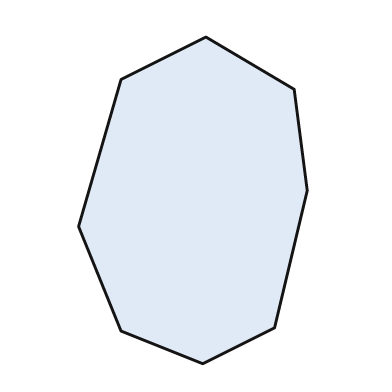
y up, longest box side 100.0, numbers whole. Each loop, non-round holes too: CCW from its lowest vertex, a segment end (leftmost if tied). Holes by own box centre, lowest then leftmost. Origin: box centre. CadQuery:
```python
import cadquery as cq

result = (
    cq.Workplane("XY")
    .moveTo(3.0, -50.0)
    .lineTo(25.0, -39.0)
    .lineTo(35.0, 3.0)
    .lineTo(31.0, 34.0)
    .lineTo(4.0, 50.0)
    .lineTo(-22.0, 37.0)
    .lineTo(-35.0, -8.0)
    .lineTo(-22.0, -40.0)
    .close()
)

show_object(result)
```